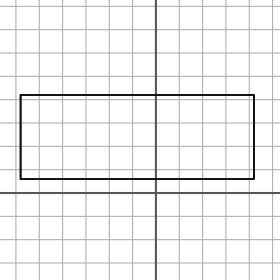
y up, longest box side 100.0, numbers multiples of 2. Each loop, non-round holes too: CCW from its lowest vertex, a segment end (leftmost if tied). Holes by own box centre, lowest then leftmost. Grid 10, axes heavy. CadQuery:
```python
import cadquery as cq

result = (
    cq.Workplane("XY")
    .moveTo(-58.0, 6.0)
    .lineTo(42.0, 6.0)
    .lineTo(42.0, 42.0)
    .lineTo(-58.0, 42.0)
    .close()
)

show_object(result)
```